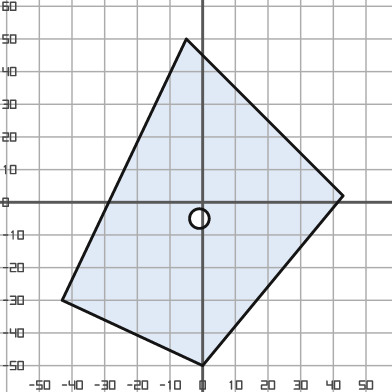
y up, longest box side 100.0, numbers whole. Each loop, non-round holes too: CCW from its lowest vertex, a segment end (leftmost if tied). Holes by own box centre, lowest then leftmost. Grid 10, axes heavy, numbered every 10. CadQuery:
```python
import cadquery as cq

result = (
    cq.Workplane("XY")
    .moveTo(0.0, -50.0)
    .lineTo(43.0, 2.0)
    .lineTo(-5.0, 50.0)
    .lineTo(-43.0, -30.0)
    .close()
    .moveTo(-1.0, -5.0)
    .circle(3.0)
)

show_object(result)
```